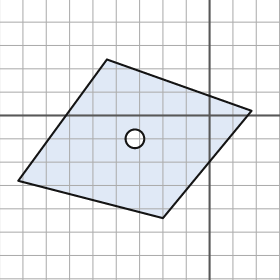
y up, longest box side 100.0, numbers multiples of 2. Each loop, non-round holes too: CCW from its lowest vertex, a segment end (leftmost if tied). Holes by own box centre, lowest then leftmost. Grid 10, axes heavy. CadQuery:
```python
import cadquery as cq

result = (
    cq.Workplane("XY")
    .moveTo(-20.0, -44.0)
    .lineTo(18.0, 2.0)
    .lineTo(-44.0, 24.0)
    .lineTo(-82.0, -28.0)
    .close()
    .moveTo(-32.0, -10.0)
    .circle(4.0)
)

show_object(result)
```